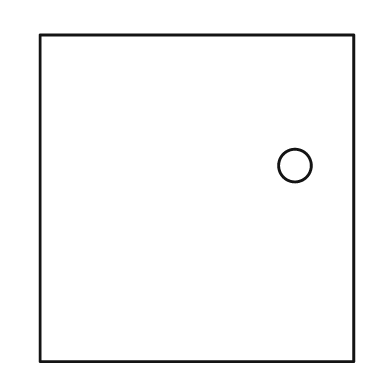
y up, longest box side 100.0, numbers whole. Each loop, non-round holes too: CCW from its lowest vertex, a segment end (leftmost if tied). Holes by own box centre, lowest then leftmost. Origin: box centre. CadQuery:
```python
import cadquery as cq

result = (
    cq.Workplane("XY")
    .moveTo(-48.0, -50.0)
    .lineTo(48.0, -50.0)
    .lineTo(48.0, 50.0)
    .lineTo(-48.0, 50.0)
    .close()
    .moveTo(30.0, 10.0)
    .circle(5.0)
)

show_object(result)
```